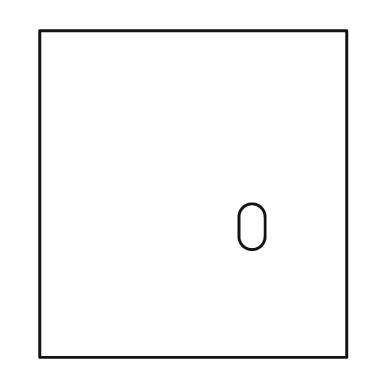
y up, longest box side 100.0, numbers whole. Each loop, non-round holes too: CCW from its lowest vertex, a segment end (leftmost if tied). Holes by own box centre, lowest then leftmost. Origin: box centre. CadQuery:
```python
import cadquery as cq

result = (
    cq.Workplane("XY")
    .moveTo(-47.0, -50.0)
    .lineTo(47.0, -50.0)
    .lineTo(47.0, 50.0)
    .lineTo(-47.0, 50.0)
    .close()
    .moveTo(14.0, -13.0)
    .threePointArc((18.0, -17.0), (22.0, -13.0))
    .lineTo(22.0, -7.0)
    .threePointArc((18.0, -3.0), (14.0, -7.0))
    .close()
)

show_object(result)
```